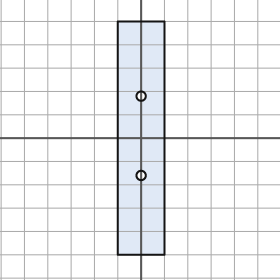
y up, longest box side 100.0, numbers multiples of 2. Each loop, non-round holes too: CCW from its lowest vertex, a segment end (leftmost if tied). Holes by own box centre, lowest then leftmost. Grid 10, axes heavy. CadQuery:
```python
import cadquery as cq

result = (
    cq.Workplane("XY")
    .moveTo(-10.0, -50.0)
    .lineTo(10.0, -50.0)
    .lineTo(10.0, 50.0)
    .lineTo(-10.0, 50.0)
    .close()
    .moveTo(0.0, -16.0)
    .circle(2.0)
    .moveTo(0.0, 18.0)
    .circle(2.0)
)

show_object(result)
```